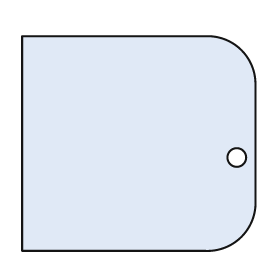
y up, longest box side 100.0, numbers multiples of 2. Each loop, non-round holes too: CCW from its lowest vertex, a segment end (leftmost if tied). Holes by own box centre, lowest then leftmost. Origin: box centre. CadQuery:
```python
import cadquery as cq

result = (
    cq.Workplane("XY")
    .moveTo(-50.0, -46.0)
    .lineTo(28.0, -46.0)
    .threePointArc((44.0, -40.0), (50.0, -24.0))
    .lineTo(50.0, 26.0)
    .threePointArc((44.0, 40.0), (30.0, 46.0))
    .lineTo(-50.0, 46.0)
    .close()
    .moveTo(42.0, -6.0)
    .circle(4.0)
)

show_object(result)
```